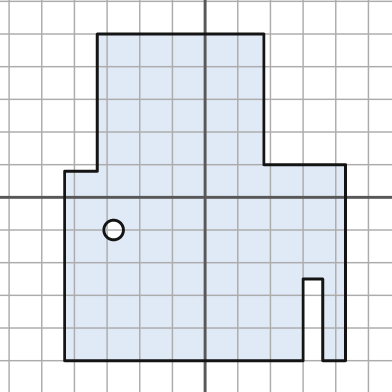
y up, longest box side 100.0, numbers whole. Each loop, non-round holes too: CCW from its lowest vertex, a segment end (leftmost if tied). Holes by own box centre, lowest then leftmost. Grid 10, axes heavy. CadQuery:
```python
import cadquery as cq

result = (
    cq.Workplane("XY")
    .moveTo(-43.0, -50.0)
    .lineTo(30.0, -50.0)
    .lineTo(30.0, -25.0)
    .lineTo(36.0, -25.0)
    .lineTo(36.0, -50.0)
    .lineTo(43.0, -50.0)
    .lineTo(43.0, 10.0)
    .lineTo(18.0, 10.0)
    .lineTo(18.0, 50.0)
    .lineTo(-33.0, 50.0)
    .lineTo(-33.0, 8.0)
    .lineTo(-43.0, 8.0)
    .close()
    .moveTo(-28.0, -10.0)
    .circle(3.0)
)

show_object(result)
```